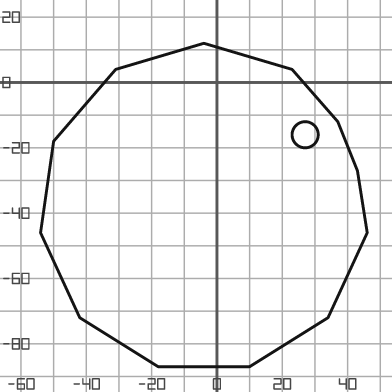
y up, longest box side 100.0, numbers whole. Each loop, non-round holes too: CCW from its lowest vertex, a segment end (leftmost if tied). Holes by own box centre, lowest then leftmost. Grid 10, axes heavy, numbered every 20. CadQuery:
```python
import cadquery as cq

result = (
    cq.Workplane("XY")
    .moveTo(-18.0, -87.0)
    .lineTo(10.0, -87.0)
    .lineTo(34.0, -72.0)
    .lineTo(46.0, -46.0)
    .lineTo(43.0, -27.0)
    .lineTo(37.0, -12.0)
    .lineTo(23.0, 4.0)
    .lineTo(-4.0, 12.0)
    .lineTo(-31.0, 4.0)
    .lineTo(-50.0, -18.0)
    .lineTo(-54.0, -46.0)
    .lineTo(-42.0, -72.0)
    .close()
    .moveTo(27.0, -16.0)
    .circle(4.0)
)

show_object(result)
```